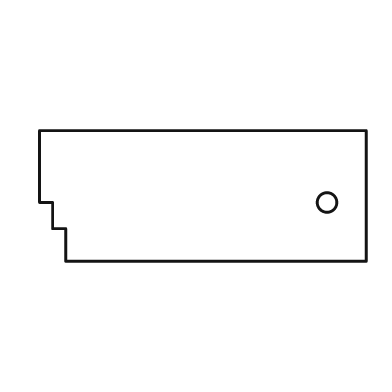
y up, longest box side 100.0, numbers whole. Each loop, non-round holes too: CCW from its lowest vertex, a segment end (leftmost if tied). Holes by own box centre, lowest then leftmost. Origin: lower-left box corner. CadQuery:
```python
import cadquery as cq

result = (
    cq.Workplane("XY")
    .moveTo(8.0, 0.0)
    .lineTo(100.0, 0.0)
    .lineTo(100.0, 40.0)
    .lineTo(0.0, 40.0)
    .lineTo(0.0, 18.0)
    .lineTo(4.0, 18.0)
    .lineTo(4.0, 10.0)
    .lineTo(8.0, 10.0)
    .close()
    .moveTo(88.0, 18.0)
    .circle(3.0)
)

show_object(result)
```